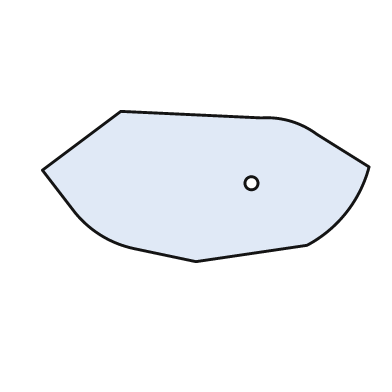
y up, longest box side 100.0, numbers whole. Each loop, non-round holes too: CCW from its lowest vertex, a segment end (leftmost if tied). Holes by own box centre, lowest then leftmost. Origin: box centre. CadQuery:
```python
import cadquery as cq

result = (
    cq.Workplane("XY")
    .moveTo(-3.0, -23.0)
    .lineTo(31.0, -18.0)
    .threePointArc((43.0, -8.0), (50.0, 6.0))
    .lineTo(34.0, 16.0)
    .threePointArc((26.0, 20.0), (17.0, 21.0))
    .lineTo(-26.0, 23.0)
    .lineTo(-50.0, 5.0)
    .lineTo(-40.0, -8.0)
    .threePointArc((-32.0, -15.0), (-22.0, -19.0))
    .close()
    .moveTo(14.0, 1.0)
    .circle(2.0)
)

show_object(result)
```